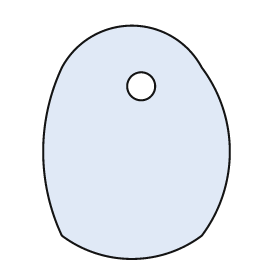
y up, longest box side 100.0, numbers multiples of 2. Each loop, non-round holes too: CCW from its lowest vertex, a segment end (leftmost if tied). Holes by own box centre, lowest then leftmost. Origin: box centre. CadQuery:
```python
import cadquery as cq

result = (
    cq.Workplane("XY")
    .moveTo(-32.0, -40.0)
    .threePointArc((-2.0, -50.0), (28.0, -40.0))
    .threePointArc((40.0, -4.0), (28.0, 32.0))
    .threePointArc((-2.0, 50.0), (-32.0, 32.0))
    .threePointArc((-40.0, -4.0), (-32.0, -40.0))
    .close()
    .moveTo(2.0, 24.0)
    .circle(6.0)
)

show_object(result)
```